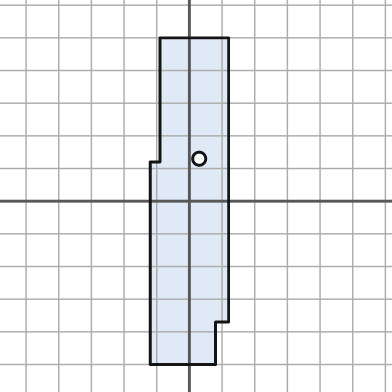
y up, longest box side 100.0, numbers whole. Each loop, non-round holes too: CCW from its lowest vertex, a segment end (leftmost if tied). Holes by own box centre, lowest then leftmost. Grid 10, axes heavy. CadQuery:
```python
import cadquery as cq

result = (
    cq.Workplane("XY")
    .moveTo(-12.0, -50.0)
    .lineTo(8.0, -50.0)
    .lineTo(8.0, -37.0)
    .lineTo(12.0, -37.0)
    .lineTo(12.0, 50.0)
    .lineTo(-9.0, 50.0)
    .lineTo(-9.0, 12.0)
    .lineTo(-12.0, 12.0)
    .close()
    .moveTo(3.0, 13.0)
    .circle(2.0)
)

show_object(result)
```